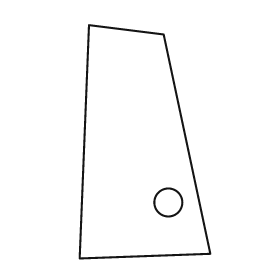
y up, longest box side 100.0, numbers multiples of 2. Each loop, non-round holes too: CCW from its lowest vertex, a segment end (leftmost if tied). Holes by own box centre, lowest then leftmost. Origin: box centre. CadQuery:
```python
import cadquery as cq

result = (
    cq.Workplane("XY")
    .moveTo(-28.0, -50.0)
    .lineTo(28.0, -48.0)
    .lineTo(8.0, 46.0)
    .lineTo(-24.0, 50.0)
    .close()
    .moveTo(10.0, -26.0)
    .circle(6.0)
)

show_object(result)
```